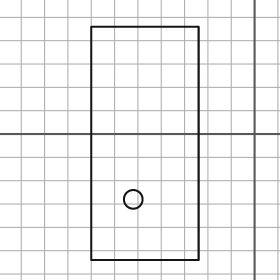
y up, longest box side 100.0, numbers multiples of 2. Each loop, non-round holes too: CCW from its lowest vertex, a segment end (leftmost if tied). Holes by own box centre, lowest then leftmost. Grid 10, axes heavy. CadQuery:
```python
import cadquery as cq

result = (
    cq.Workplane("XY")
    .moveTo(-70.0, -54.0)
    .lineTo(-24.0, -54.0)
    .lineTo(-24.0, 46.0)
    .lineTo(-70.0, 46.0)
    .close()
    .moveTo(-52.0, -28.0)
    .circle(4.0)
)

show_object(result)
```